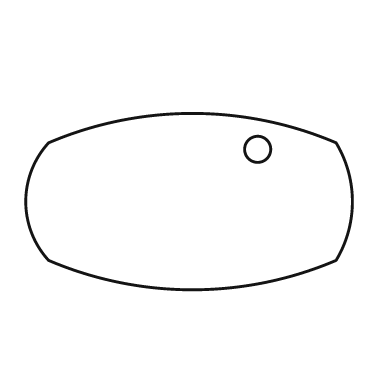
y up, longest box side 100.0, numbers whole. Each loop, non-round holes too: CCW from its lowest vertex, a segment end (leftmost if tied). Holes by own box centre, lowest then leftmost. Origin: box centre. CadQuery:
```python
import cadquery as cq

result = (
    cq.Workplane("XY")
    .moveTo(-43.0, -18.0)
    .threePointArc((1.0, -27.0), (45.0, -18.0))
    .threePointArc((50.0, 0.0), (45.0, 18.0))
    .threePointArc((1.0, 27.0), (-43.0, 18.0))
    .threePointArc((-50.0, 0.0), (-43.0, -18.0))
    .close()
    .moveTo(21.0, 16.0)
    .circle(4.0)
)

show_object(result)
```